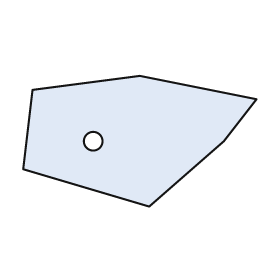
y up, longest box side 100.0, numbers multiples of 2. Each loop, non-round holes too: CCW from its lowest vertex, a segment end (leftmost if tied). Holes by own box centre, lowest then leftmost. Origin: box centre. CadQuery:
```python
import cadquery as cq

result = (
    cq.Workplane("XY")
    .moveTo(4.0, -28.0)
    .lineTo(36.0, 0.0)
    .lineTo(50.0, 18.0)
    .lineTo(0.0, 28.0)
    .lineTo(-46.0, 22.0)
    .lineTo(-50.0, -12.0)
    .close()
    .moveTo(-20.0, 0.0)
    .circle(4.0)
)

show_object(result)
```